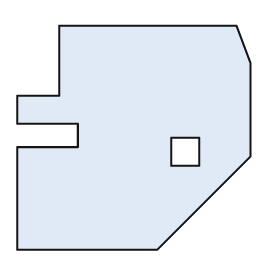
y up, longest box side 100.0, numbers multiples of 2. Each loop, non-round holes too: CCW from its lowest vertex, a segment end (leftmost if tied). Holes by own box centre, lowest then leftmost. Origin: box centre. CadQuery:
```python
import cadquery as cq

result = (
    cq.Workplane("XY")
    .moveTo(-50.0, -48.0)
    .lineTo(10.0, -48.0)
    .lineTo(50.0, -8.0)
    .lineTo(50.0, 32.0)
    .lineTo(44.0, 48.0)
    .lineTo(-32.0, 48.0)
    .lineTo(-32.0, 18.0)
    .lineTo(-50.0, 18.0)
    .lineTo(-50.0, 6.0)
    .lineTo(-24.0, 6.0)
    .lineTo(-24.0, -4.0)
    .lineTo(-50.0, -4.0)
    .close()
    .moveTo(16.0, -12.0)
    .lineTo(28.0, -12.0)
    .lineTo(28.0, 0.0)
    .lineTo(16.0, 0.0)
    .close()
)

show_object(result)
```